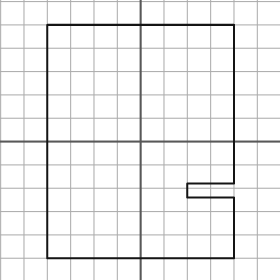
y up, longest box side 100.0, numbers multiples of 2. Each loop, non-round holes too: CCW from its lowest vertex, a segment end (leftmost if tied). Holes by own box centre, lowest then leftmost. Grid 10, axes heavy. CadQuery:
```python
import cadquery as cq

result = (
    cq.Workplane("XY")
    .moveTo(-40.0, -50.0)
    .lineTo(40.0, -50.0)
    .lineTo(40.0, -24.0)
    .lineTo(20.0, -24.0)
    .lineTo(20.0, -18.0)
    .lineTo(40.0, -18.0)
    .lineTo(40.0, 50.0)
    .lineTo(-40.0, 50.0)
    .close()
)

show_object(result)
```